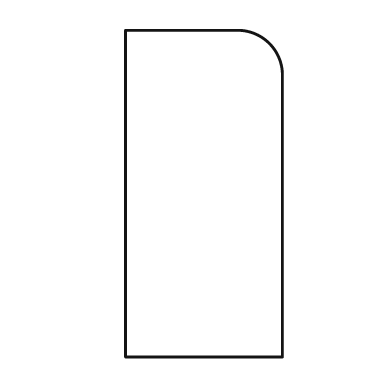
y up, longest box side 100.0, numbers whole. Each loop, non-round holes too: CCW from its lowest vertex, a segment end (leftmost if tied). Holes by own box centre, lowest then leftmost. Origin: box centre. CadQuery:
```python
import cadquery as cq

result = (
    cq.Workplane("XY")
    .moveTo(-24.0, -50.0)
    .lineTo(24.0, -50.0)
    .lineTo(24.0, 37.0)
    .threePointArc((20.0, 46.0), (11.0, 50.0))
    .lineTo(-24.0, 50.0)
    .close()
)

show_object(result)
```